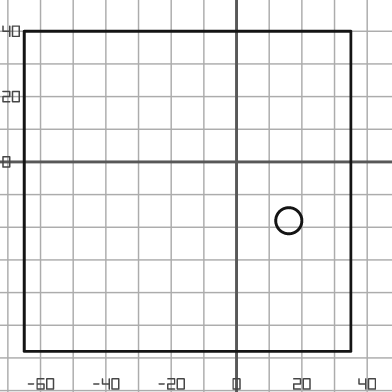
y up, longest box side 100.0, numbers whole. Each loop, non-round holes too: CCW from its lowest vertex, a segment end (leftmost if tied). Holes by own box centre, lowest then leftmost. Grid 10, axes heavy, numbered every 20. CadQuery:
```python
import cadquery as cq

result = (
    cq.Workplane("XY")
    .moveTo(-65.0, -58.0)
    .lineTo(35.0, -58.0)
    .lineTo(35.0, 40.0)
    .lineTo(-65.0, 40.0)
    .close()
    .moveTo(16.0, -18.0)
    .circle(4.0)
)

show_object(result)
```